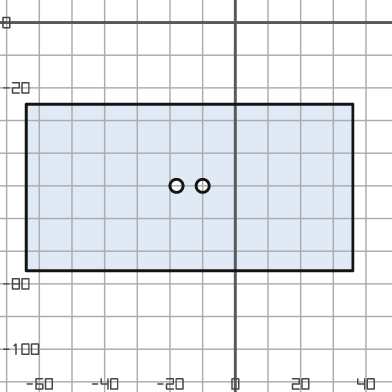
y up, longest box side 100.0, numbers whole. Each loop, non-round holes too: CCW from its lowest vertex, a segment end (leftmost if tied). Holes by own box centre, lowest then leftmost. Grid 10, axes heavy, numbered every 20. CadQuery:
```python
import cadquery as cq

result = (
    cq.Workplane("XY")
    .moveTo(-64.0, -76.0)
    .lineTo(36.0, -76.0)
    .lineTo(36.0, -25.0)
    .lineTo(-64.0, -25.0)
    .close()
    .moveTo(-18.0, -50.0)
    .circle(2.0)
    .moveTo(-10.0, -50.0)
    .circle(2.0)
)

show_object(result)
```